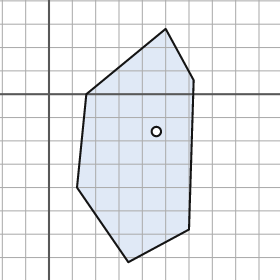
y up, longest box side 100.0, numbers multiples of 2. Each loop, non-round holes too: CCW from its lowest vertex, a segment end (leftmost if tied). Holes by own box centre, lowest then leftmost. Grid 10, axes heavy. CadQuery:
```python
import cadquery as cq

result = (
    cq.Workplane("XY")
    .moveTo(34.0, -72.0)
    .lineTo(60.0, -58.0)
    .lineTo(62.0, 6.0)
    .lineTo(50.0, 28.0)
    .lineTo(16.0, 0.0)
    .lineTo(12.0, -40.0)
    .close()
    .moveTo(46.0, -16.0)
    .circle(2.0)
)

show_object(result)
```